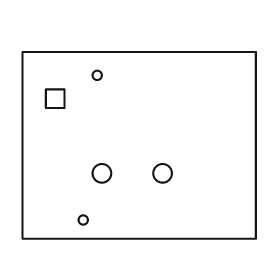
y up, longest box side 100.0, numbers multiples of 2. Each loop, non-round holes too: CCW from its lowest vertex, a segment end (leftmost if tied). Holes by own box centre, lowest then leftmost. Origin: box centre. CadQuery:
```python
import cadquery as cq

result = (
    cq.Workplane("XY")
    .moveTo(-50.0, -40.0)
    .lineTo(50.0, -40.0)
    .lineTo(50.0, 40.0)
    .lineTo(-50.0, 40.0)
    .close()
    .moveTo(-24.0, -32.0)
    .circle(2.0)
    .moveTo(-16.0, -12.0)
    .circle(4.0)
    .moveTo(10.0, -12.0)
    .circle(4.0)
    .moveTo(-40.0, 16.0)
    .lineTo(-32.0, 16.0)
    .lineTo(-32.0, 24.0)
    .lineTo(-40.0, 24.0)
    .close()
    .moveTo(-18.0, 30.0)
    .circle(2.0)
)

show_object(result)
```